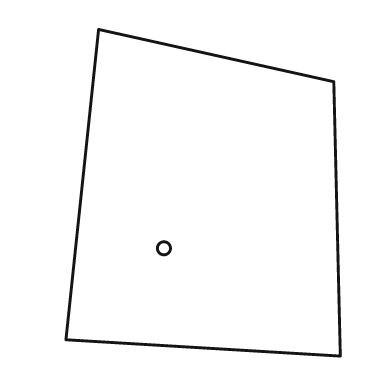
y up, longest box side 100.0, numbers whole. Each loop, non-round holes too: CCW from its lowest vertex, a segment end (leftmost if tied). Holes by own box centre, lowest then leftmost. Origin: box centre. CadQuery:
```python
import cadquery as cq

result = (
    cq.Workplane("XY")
    .moveTo(42.0, -50.0)
    .lineTo(40.0, 34.0)
    .lineTo(-32.0, 50.0)
    .lineTo(-42.0, -45.0)
    .close()
    .moveTo(-12.0, -17.0)
    .circle(2.0)
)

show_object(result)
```